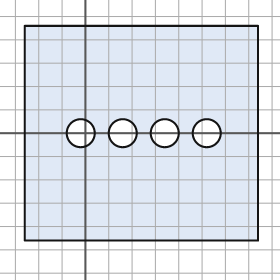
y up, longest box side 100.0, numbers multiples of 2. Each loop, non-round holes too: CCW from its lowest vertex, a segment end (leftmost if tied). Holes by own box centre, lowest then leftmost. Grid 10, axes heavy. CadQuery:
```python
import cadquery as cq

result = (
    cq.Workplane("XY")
    .moveTo(-26.0, -46.0)
    .lineTo(74.0, -46.0)
    .lineTo(74.0, 46.0)
    .lineTo(-26.0, 46.0)
    .close()
    .moveTo(-2.0, 0.0)
    .circle(6.0)
    .moveTo(16.0, 0.0)
    .circle(6.0)
    .moveTo(34.0, 0.0)
    .circle(6.0)
    .moveTo(52.0, 0.0)
    .circle(6.0)
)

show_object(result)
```